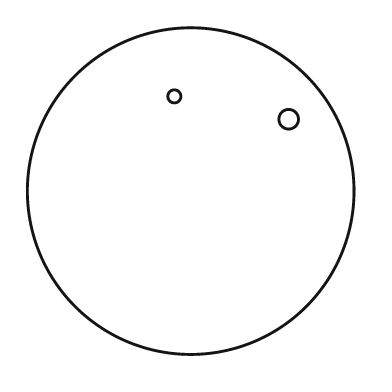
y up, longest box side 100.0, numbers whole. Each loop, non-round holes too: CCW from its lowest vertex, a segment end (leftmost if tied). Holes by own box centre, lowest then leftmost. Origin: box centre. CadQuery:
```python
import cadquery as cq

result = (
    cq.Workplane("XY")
    .moveTo(0.0, 0.0)
    .circle(50.0)
    .moveTo(30.0, 22.0)
    .circle(3.0)
    .moveTo(-5.0, 29.0)
    .circle(2.0)
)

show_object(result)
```